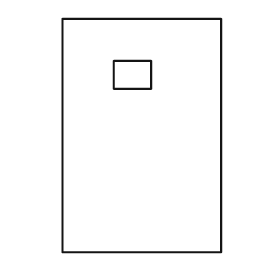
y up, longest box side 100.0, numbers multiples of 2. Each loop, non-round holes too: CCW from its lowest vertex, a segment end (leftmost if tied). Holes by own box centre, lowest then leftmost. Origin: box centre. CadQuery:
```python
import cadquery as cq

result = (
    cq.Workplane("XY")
    .moveTo(-34.0, -50.0)
    .lineTo(34.0, -50.0)
    .lineTo(34.0, 50.0)
    .lineTo(-34.0, 50.0)
    .close()
    .moveTo(-12.0, 20.0)
    .lineTo(4.0, 20.0)
    .lineTo(4.0, 32.0)
    .lineTo(-12.0, 32.0)
    .close()
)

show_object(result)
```